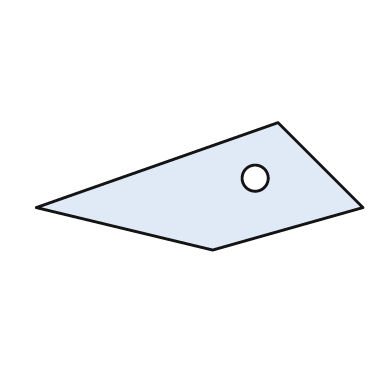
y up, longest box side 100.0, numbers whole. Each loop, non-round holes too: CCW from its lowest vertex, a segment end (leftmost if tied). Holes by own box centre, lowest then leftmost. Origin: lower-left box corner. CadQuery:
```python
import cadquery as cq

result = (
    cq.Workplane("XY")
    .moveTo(54.0, 0.0)
    .lineTo(100.0, 13.0)
    .lineTo(74.0, 39.0)
    .lineTo(0.0, 13.0)
    .close()
    .moveTo(67.0, 22.0)
    .circle(4.0)
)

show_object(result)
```